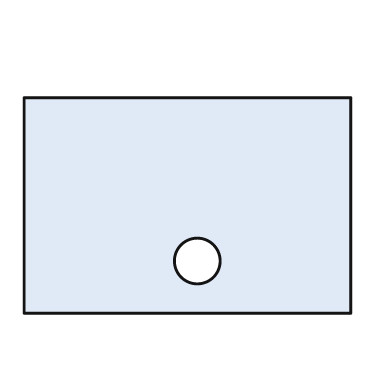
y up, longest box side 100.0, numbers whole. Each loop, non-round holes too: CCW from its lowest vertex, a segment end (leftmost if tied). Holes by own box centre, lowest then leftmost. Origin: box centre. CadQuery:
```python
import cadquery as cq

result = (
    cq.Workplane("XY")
    .moveTo(-50.0, -33.0)
    .lineTo(50.0, -33.0)
    .lineTo(50.0, 33.0)
    .lineTo(-50.0, 33.0)
    .close()
    .moveTo(3.0, -17.0)
    .circle(7.0)
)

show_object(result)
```